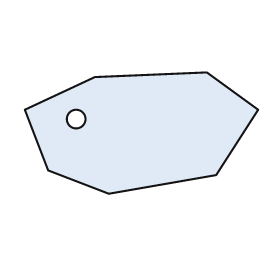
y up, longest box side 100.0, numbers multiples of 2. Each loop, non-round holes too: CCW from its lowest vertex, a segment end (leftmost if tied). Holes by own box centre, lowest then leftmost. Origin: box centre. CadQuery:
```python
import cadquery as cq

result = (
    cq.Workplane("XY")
    .moveTo(-14.0, -26.0)
    .lineTo(32.0, -18.0)
    .lineTo(50.0, 10.0)
    .lineTo(28.0, 26.0)
    .lineTo(-20.0, 24.0)
    .lineTo(-50.0, 10.0)
    .lineTo(-40.0, -16.0)
    .close()
    .moveTo(-28.0, 6.0)
    .circle(4.0)
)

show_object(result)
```